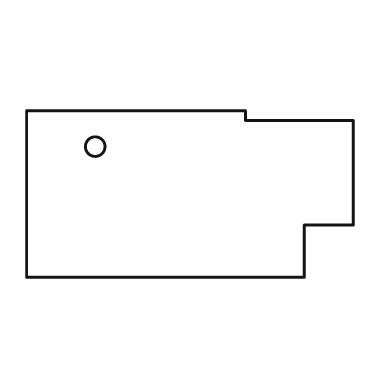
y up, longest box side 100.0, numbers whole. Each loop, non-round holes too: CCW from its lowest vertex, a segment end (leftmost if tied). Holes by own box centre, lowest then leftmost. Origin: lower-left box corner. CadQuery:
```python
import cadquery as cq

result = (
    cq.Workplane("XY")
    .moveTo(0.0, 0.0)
    .lineTo(85.0, 0.0)
    .lineTo(85.0, 16.0)
    .lineTo(100.0, 16.0)
    .lineTo(100.0, 48.0)
    .lineTo(67.0, 48.0)
    .lineTo(67.0, 51.0)
    .lineTo(0.0, 51.0)
    .close()
    .moveTo(21.0, 40.0)
    .circle(3.0)
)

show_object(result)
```